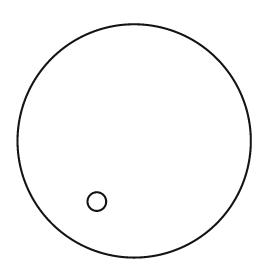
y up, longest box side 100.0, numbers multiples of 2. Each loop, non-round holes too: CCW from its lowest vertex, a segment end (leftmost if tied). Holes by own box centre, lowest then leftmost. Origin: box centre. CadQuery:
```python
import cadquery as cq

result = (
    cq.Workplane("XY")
    .moveTo(0.0, 0.0)
    .circle(50.0)
    .moveTo(-16.0, -26.0)
    .circle(4.0)
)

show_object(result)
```